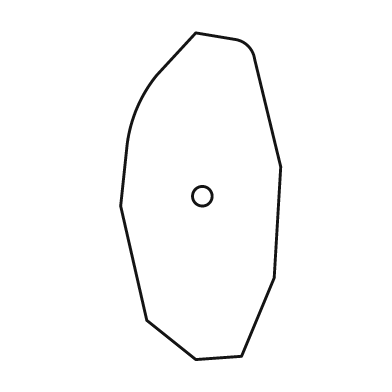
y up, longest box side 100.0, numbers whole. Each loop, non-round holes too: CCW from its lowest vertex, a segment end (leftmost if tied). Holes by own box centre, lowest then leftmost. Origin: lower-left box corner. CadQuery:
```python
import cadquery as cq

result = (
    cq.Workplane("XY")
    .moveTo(23.0, 0.0)
    .lineTo(37.0, 1.0)
    .lineTo(47.0, 25.0)
    .lineTo(49.0, 59.0)
    .lineTo(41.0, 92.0)
    .threePointArc((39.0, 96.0), (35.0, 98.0))
    .lineTo(23.0, 100.0)
    .lineTo(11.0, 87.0)
    .threePointArc((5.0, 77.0), (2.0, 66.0))
    .lineTo(0.0, 47.0)
    .lineTo(8.0, 12.0)
    .close()
    .moveTo(25.0, 50.0)
    .circle(3.0)
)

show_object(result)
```